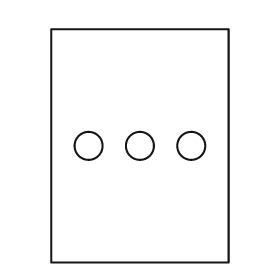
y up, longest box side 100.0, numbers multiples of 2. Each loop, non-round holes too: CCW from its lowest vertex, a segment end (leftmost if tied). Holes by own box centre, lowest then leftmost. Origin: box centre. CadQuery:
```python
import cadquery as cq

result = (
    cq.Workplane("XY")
    .moveTo(-38.0, -50.0)
    .lineTo(38.0, -50.0)
    .lineTo(38.0, 50.0)
    .lineTo(-38.0, 50.0)
    .close()
    .moveTo(-22.0, 0.0)
    .circle(6.0)
    .moveTo(0.0, 0.0)
    .circle(6.0)
    .moveTo(22.0, 0.0)
    .circle(6.0)
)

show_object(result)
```